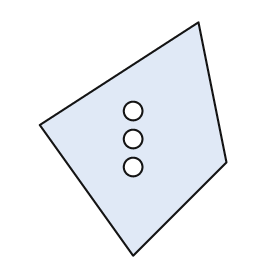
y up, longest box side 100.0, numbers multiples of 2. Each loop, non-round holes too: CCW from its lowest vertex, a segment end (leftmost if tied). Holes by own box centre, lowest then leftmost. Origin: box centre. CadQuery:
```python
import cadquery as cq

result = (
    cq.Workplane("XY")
    .moveTo(0.0, -50.0)
    .lineTo(40.0, -10.0)
    .lineTo(28.0, 50.0)
    .lineTo(-40.0, 6.0)
    .close()
    .moveTo(0.0, -12.0)
    .circle(4.0)
    .moveTo(0.0, 0.0)
    .circle(4.0)
    .moveTo(0.0, 12.0)
    .circle(4.0)
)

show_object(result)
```